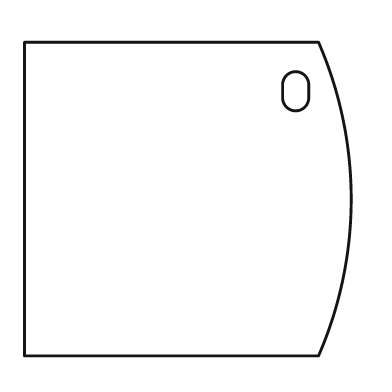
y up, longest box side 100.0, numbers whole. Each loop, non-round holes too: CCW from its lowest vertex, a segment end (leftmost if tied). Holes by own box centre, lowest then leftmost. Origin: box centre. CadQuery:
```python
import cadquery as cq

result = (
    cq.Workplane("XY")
    .moveTo(-50.0, -48.0)
    .lineTo(40.0, -48.0)
    .threePointArc((50.0, 0.0), (40.0, 48.0))
    .lineTo(-50.0, 48.0)
    .close()
    .moveTo(29.0, 31.0)
    .threePointArc((33.0, 27.0), (37.0, 31.0))
    .lineTo(37.0, 35.0)
    .threePointArc((33.0, 39.0), (29.0, 35.0))
    .close()
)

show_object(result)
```